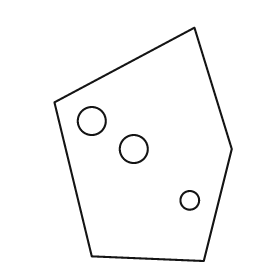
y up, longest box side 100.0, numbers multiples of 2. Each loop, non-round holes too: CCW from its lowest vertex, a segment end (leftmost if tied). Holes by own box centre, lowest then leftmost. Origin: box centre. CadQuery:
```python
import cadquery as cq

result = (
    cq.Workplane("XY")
    .moveTo(26.0, -50.0)
    .lineTo(38.0, -2.0)
    .lineTo(22.0, 50.0)
    .lineTo(-38.0, 18.0)
    .lineTo(-22.0, -48.0)
    .close()
    .moveTo(20.0, -24.0)
    .circle(4.0)
    .moveTo(-4.0, -2.0)
    .circle(6.0)
    .moveTo(-22.0, 10.0)
    .circle(6.0)
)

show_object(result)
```